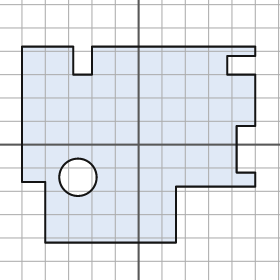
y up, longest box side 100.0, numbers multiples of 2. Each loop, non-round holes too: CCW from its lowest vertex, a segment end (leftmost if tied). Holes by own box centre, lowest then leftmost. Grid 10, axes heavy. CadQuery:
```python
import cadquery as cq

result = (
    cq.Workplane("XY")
    .moveTo(-40.0, -42.0)
    .lineTo(16.0, -42.0)
    .lineTo(16.0, -18.0)
    .lineTo(50.0, -18.0)
    .lineTo(50.0, -12.0)
    .lineTo(42.0, -12.0)
    .lineTo(42.0, 8.0)
    .lineTo(50.0, 8.0)
    .lineTo(50.0, 30.0)
    .lineTo(38.0, 30.0)
    .lineTo(38.0, 38.0)
    .lineTo(50.0, 38.0)
    .lineTo(50.0, 42.0)
    .lineTo(-20.0, 42.0)
    .lineTo(-20.0, 30.0)
    .lineTo(-28.0, 30.0)
    .lineTo(-28.0, 42.0)
    .lineTo(-50.0, 42.0)
    .lineTo(-50.0, -16.0)
    .lineTo(-40.0, -16.0)
    .close()
    .moveTo(-26.0, -14.0)
    .circle(8.0)
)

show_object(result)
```